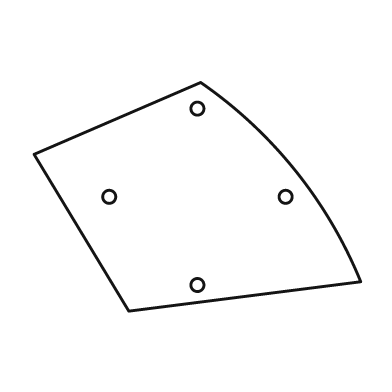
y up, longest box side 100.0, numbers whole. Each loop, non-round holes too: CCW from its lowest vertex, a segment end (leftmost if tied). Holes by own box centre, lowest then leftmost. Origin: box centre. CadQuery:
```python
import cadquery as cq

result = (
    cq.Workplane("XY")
    .moveTo(-21.0, -35.0)
    .lineTo(50.0, -26.0)
    .threePointArc((30.0, 8.0), (1.0, 35.0))
    .lineTo(-50.0, 13.0)
    .close()
    .moveTo(0.0, -27.0)
    .circle(2.0)
    .moveTo(-27.0, 0.0)
    .circle(2.0)
    .moveTo(27.0, 0.0)
    .circle(2.0)
    .moveTo(0.0, 27.0)
    .circle(2.0)
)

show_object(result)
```